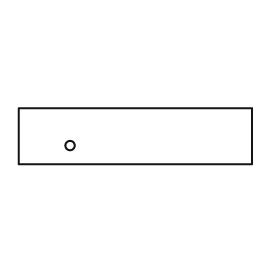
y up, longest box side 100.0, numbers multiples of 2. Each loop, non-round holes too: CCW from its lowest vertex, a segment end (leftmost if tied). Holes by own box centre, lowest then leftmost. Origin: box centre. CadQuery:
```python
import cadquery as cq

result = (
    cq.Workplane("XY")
    .moveTo(-50.0, -12.0)
    .lineTo(50.0, -12.0)
    .lineTo(50.0, 12.0)
    .lineTo(-50.0, 12.0)
    .close()
    .moveTo(-28.0, -4.0)
    .circle(2.0)
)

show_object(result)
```